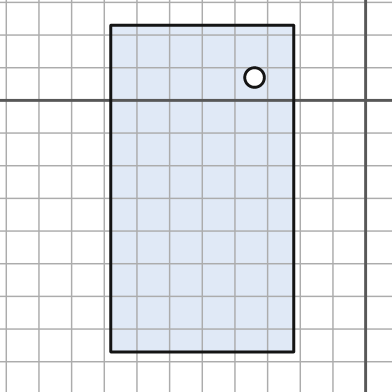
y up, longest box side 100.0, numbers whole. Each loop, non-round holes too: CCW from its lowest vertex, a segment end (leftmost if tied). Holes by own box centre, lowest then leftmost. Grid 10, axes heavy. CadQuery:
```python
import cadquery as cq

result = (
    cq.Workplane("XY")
    .moveTo(-78.0, -77.0)
    .lineTo(-22.0, -77.0)
    .lineTo(-22.0, 23.0)
    .lineTo(-78.0, 23.0)
    .close()
    .moveTo(-34.0, 7.0)
    .circle(3.0)
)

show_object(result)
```